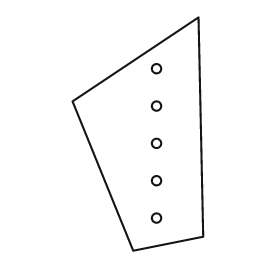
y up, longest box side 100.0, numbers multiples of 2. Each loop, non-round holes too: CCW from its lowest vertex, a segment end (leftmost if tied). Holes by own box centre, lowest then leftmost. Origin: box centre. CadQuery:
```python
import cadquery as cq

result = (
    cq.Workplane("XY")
    .moveTo(-2.0, -50.0)
    .lineTo(28.0, -44.0)
    .lineTo(26.0, 50.0)
    .lineTo(-28.0, 14.0)
    .close()
    .moveTo(8.0, -36.0)
    .circle(2.0)
    .moveTo(8.0, -20.0)
    .circle(2.0)
    .moveTo(8.0, -4.0)
    .circle(2.0)
    .moveTo(8.0, 12.0)
    .circle(2.0)
    .moveTo(8.0, 28.0)
    .circle(2.0)
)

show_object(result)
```